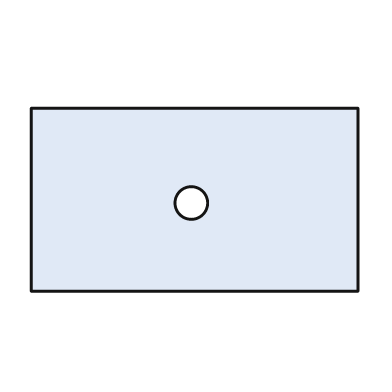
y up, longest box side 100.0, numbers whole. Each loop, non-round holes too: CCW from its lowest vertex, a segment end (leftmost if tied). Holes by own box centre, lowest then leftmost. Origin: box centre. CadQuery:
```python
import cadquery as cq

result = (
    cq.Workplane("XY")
    .moveTo(-50.0, -28.0)
    .lineTo(50.0, -28.0)
    .lineTo(50.0, 28.0)
    .lineTo(-50.0, 28.0)
    .close()
    .moveTo(-1.0, -1.0)
    .circle(5.0)
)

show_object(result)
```